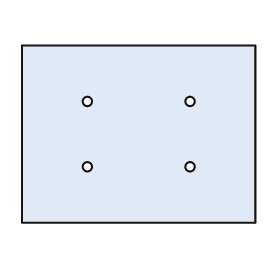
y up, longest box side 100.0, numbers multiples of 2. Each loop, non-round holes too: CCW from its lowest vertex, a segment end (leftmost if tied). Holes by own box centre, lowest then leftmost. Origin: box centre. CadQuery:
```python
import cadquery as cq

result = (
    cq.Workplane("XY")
    .moveTo(-50.0, -38.0)
    .lineTo(50.0, -38.0)
    .lineTo(50.0, 38.0)
    .lineTo(-50.0, 38.0)
    .close()
    .moveTo(-22.0, -14.0)
    .circle(2.0)
    .moveTo(22.0, -14.0)
    .circle(2.0)
    .moveTo(-22.0, 14.0)
    .circle(2.0)
    .moveTo(22.0, 14.0)
    .circle(2.0)
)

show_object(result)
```